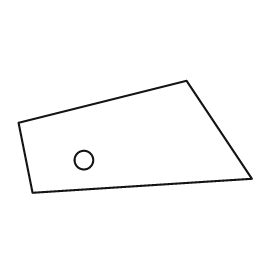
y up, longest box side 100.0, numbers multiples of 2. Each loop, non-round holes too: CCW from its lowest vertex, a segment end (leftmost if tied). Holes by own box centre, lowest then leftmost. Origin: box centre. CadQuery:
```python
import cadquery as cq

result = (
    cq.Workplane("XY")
    .moveTo(-44.0, -24.0)
    .lineTo(50.0, -18.0)
    .lineTo(22.0, 24.0)
    .lineTo(-50.0, 6.0)
    .close()
    .moveTo(-22.0, -10.0)
    .circle(4.0)
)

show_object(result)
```